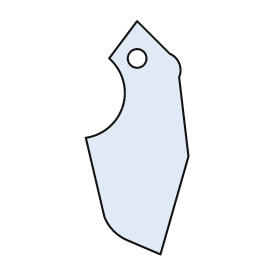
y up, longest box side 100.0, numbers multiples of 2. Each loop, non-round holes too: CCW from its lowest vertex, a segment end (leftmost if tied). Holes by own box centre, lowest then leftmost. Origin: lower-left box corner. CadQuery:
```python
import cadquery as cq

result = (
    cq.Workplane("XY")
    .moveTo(32.0, 0.0)
    .lineTo(44.0, 42.0)
    .lineTo(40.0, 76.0)
    .threePointArc((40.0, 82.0), (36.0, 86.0))
    .lineTo(22.0, 100.0)
    .lineTo(10.0, 84.0)
    .threePointArc((16.0, 64.0), (0.0, 50.0))
    .lineTo(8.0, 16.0)
    .threePointArc((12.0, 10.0), (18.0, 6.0))
    .close()
    .moveTo(22.0, 84.0)
    .circle(4.0)
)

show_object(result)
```